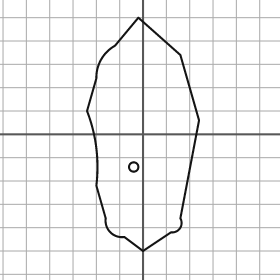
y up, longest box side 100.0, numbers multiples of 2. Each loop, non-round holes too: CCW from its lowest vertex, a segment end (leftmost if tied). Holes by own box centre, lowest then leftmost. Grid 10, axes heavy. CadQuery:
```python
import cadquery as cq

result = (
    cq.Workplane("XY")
    .moveTo(0.0, -50.0)
    .lineTo(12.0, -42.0)
    .threePointArc((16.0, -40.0), (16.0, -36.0))
    .lineTo(24.0, 6.0)
    .lineTo(16.0, 34.0)
    .lineTo(-2.0, 50.0)
    .lineTo(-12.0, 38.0)
    .threePointArc((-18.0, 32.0), (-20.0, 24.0))
    .lineTo(-24.0, 10.0)
    .threePointArc((-20.0, -6.0), (-20.0, -22.0))
    .lineTo(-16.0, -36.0)
    .threePointArc((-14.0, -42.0), (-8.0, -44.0))
    .close()
    .moveTo(-4.0, -14.0)
    .circle(2.0)
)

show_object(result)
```